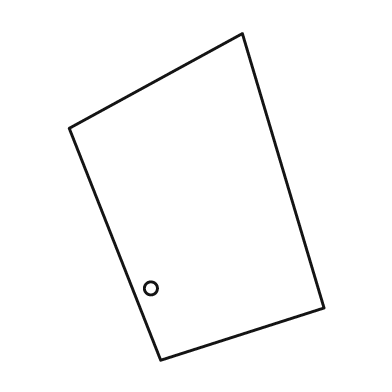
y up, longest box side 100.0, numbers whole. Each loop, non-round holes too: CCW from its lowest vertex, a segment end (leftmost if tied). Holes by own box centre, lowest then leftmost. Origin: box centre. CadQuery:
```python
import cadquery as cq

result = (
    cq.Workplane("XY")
    .moveTo(-11.0, -50.0)
    .lineTo(39.0, -34.0)
    .lineTo(14.0, 50.0)
    .lineTo(-39.0, 21.0)
    .close()
    .moveTo(-14.0, -28.0)
    .circle(2.0)
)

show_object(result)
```